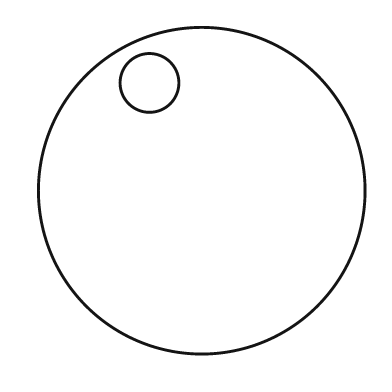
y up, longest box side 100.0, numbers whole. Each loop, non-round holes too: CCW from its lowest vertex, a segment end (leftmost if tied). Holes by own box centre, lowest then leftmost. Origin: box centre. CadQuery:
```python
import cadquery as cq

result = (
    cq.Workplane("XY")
    .moveTo(0.0, 0.0)
    .circle(50.0)
    .moveTo(-16.0, 33.0)
    .circle(9.0)
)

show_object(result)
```